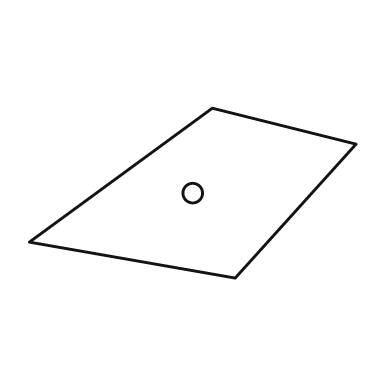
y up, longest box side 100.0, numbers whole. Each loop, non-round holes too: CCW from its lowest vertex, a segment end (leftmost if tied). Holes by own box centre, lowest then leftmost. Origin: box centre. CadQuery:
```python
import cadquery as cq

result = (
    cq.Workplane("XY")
    .moveTo(13.0, -26.0)
    .lineTo(50.0, 15.0)
    .lineTo(6.0, 26.0)
    .lineTo(-50.0, -15.0)
    .close()
    .moveTo(0.0, 0.0)
    .circle(3.0)
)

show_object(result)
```